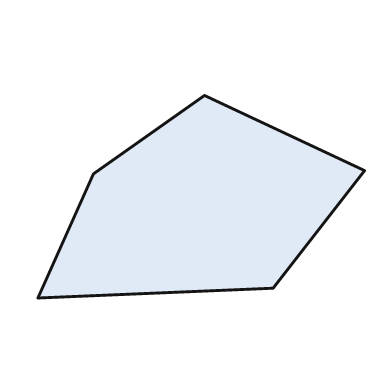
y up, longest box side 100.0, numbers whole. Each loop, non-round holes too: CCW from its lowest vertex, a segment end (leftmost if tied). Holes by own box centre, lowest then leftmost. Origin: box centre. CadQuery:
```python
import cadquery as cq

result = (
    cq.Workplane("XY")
    .moveTo(-50.0, -31.0)
    .lineTo(22.0, -28.0)
    .lineTo(50.0, 8.0)
    .lineTo(1.0, 31.0)
    .lineTo(-33.0, 7.0)
    .close()
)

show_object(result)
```